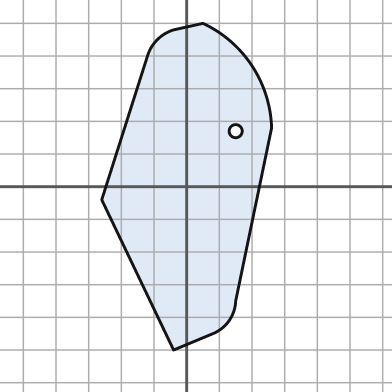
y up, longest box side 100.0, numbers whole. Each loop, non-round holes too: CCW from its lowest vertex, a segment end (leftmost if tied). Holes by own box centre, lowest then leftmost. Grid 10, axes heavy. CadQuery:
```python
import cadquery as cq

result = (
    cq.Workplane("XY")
    .moveTo(-4.0, -50.0)
    .lineTo(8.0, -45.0)
    .threePointArc((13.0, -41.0), (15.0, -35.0))
    .lineTo(26.0, 18.0)
    .threePointArc((20.0, 37.0), (5.0, 50.0))
    .lineTo(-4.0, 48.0)
    .threePointArc((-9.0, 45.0), (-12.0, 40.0))
    .lineTo(-26.0, -4.0)
    .close()
    .moveTo(15.0, 17.0)
    .circle(2.0)
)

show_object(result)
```